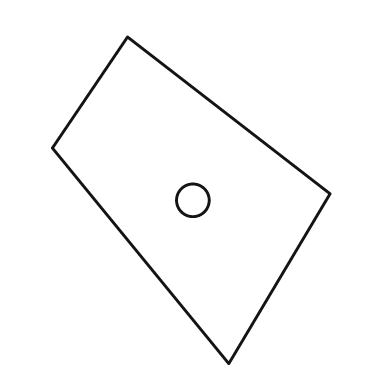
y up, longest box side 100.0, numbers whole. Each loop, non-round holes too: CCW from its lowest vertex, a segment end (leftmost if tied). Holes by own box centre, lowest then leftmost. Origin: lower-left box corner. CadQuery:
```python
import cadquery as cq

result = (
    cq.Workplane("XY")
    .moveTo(54.0, 0.0)
    .lineTo(85.0, 52.0)
    .lineTo(23.0, 100.0)
    .lineTo(0.0, 66.0)
    .close()
    .moveTo(43.0, 50.0)
    .circle(5.0)
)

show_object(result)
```